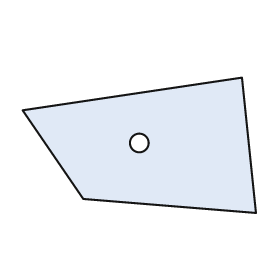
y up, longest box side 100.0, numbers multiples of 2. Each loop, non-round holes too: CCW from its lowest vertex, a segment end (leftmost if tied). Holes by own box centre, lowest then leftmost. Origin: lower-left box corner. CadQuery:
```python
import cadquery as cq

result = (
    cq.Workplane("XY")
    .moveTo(100.0, 0.0)
    .lineTo(94.0, 58.0)
    .lineTo(0.0, 44.0)
    .lineTo(26.0, 6.0)
    .close()
    .moveTo(50.0, 30.0)
    .circle(4.0)
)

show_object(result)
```